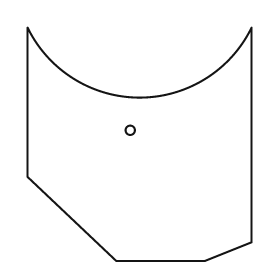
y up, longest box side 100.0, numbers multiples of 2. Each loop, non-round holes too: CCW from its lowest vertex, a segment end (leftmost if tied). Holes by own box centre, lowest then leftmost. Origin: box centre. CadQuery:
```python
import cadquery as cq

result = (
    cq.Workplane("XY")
    .moveTo(-10.0, -50.0)
    .lineTo(28.0, -50.0)
    .lineTo(48.0, -42.0)
    .lineTo(48.0, 50.0)
    .threePointArc((0.0, 20.0), (-48.0, 50.0))
    .lineTo(-48.0, -14.0)
    .close()
    .moveTo(-4.0, 6.0)
    .circle(2.0)
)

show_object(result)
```